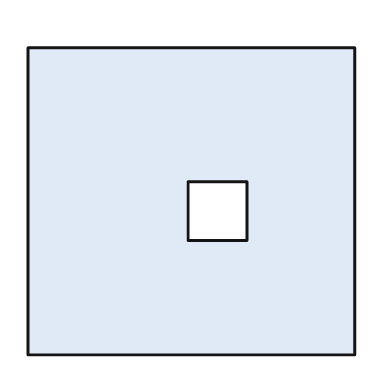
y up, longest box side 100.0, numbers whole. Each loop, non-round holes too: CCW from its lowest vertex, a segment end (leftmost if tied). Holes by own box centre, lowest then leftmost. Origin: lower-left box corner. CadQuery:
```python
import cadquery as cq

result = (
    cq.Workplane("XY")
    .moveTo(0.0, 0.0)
    .lineTo(100.0, 0.0)
    .lineTo(100.0, 94.0)
    .lineTo(0.0, 94.0)
    .close()
    .moveTo(49.0, 35.0)
    .lineTo(67.0, 35.0)
    .lineTo(67.0, 53.0)
    .lineTo(49.0, 53.0)
    .close()
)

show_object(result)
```